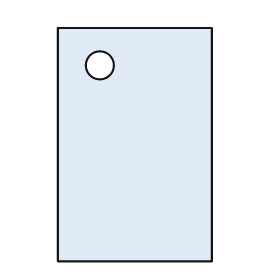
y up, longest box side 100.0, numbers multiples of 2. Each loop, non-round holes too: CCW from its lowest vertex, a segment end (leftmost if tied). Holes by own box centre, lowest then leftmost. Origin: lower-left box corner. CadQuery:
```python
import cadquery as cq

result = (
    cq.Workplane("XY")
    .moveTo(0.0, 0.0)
    .lineTo(66.0, 0.0)
    .lineTo(66.0, 100.0)
    .lineTo(0.0, 100.0)
    .close()
    .moveTo(18.0, 84.0)
    .circle(6.0)
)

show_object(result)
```